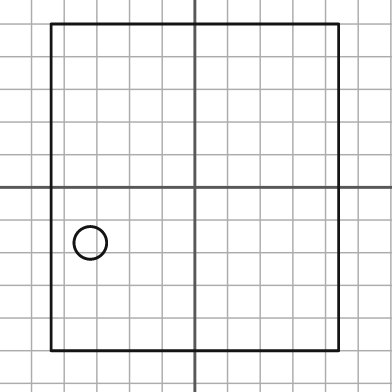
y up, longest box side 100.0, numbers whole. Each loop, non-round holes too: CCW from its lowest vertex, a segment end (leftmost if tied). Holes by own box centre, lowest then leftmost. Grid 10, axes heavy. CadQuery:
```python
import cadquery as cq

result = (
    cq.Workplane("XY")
    .moveTo(-44.0, -50.0)
    .lineTo(44.0, -50.0)
    .lineTo(44.0, 50.0)
    .lineTo(-44.0, 50.0)
    .close()
    .moveTo(-32.0, -17.0)
    .circle(5.0)
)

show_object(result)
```